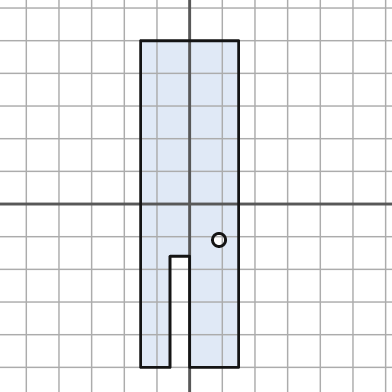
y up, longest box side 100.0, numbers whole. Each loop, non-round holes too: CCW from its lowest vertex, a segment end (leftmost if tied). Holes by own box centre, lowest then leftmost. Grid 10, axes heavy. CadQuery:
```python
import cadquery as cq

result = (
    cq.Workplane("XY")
    .moveTo(-15.0, -50.0)
    .lineTo(-6.0, -50.0)
    .lineTo(-6.0, -16.0)
    .lineTo(0.0, -16.0)
    .lineTo(0.0, -50.0)
    .lineTo(15.0, -50.0)
    .lineTo(15.0, 50.0)
    .lineTo(-15.0, 50.0)
    .close()
    .moveTo(9.0, -11.0)
    .circle(2.0)
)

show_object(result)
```